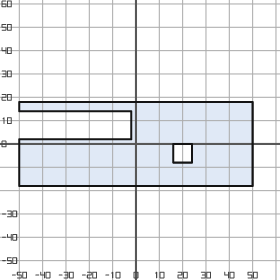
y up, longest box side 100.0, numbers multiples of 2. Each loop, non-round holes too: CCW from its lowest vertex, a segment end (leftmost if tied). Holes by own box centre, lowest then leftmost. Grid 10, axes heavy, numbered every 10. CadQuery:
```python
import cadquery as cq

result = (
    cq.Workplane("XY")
    .moveTo(-50.0, -18.0)
    .lineTo(50.0, -18.0)
    .lineTo(50.0, 18.0)
    .lineTo(-50.0, 18.0)
    .lineTo(-50.0, 14.0)
    .lineTo(-2.0, 14.0)
    .lineTo(-2.0, 2.0)
    .lineTo(-50.0, 2.0)
    .close()
    .moveTo(16.0, -8.0)
    .lineTo(24.0, -8.0)
    .lineTo(24.0, 0.0)
    .lineTo(16.0, 0.0)
    .close()
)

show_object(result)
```